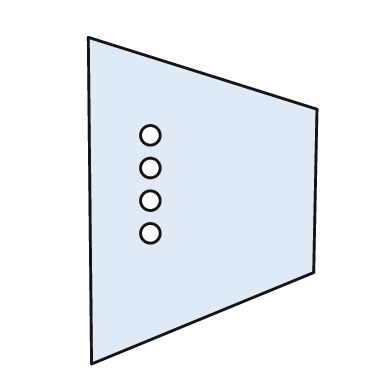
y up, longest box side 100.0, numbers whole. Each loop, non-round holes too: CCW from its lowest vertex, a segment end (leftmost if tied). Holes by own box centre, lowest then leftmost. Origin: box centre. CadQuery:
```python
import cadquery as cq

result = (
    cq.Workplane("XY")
    .moveTo(-34.0, -50.0)
    .lineTo(34.0, -22.0)
    .lineTo(35.0, 28.0)
    .lineTo(-35.0, 50.0)
    .close()
    .moveTo(-16.0, -10.0)
    .circle(3.0)
    .moveTo(-16.0, 0.0)
    .circle(3.0)
    .moveTo(-16.0, 10.0)
    .circle(3.0)
    .moveTo(-16.0, 20.0)
    .circle(3.0)
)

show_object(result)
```